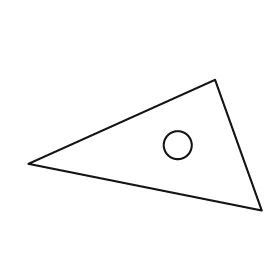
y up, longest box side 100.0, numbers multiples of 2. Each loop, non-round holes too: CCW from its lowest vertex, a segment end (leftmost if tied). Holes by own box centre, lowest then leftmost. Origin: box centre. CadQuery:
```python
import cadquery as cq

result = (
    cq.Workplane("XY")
    .moveTo(50.0, -28.0)
    .lineTo(30.0, 28.0)
    .lineTo(-50.0, -8.0)
    .close()
    .moveTo(14.0, 0.0)
    .circle(6.0)
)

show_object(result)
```